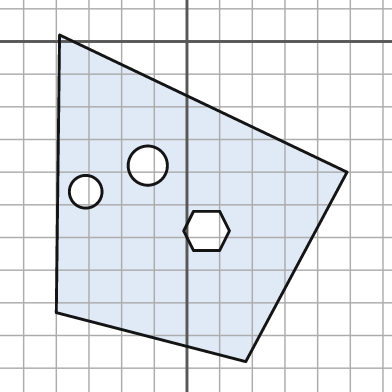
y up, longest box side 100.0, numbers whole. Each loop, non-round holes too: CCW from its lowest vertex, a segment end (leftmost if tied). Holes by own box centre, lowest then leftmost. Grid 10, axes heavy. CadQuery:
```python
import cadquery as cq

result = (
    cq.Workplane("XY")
    .moveTo(18.0, -98.0)
    .lineTo(49.0, -40.0)
    .lineTo(-39.0, 2.0)
    .lineTo(-40.0, -83.0)
    .close()
    .moveTo(2.0, -64.0)
    .lineTo(10.0, -64.0)
    .lineTo(13.0, -58.0)
    .lineTo(10.0, -52.0)
    .lineTo(2.0, -52.0)
    .lineTo(-1.0, -58.0)
    .close()
    .moveTo(-31.0, -46.0)
    .circle(5.0)
    .moveTo(-12.0, -38.0)
    .circle(6.0)
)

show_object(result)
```